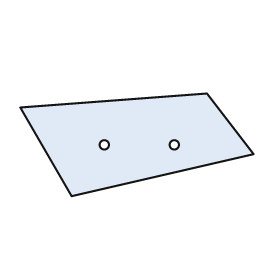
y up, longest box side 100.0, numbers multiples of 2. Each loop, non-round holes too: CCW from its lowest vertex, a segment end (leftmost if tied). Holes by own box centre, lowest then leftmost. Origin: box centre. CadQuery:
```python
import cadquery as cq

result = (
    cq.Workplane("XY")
    .moveTo(-28.0, -22.0)
    .lineTo(50.0, -4.0)
    .lineTo(30.0, 22.0)
    .lineTo(-50.0, 16.0)
    .close()
    .moveTo(-14.0, 0.0)
    .circle(2.0)
    .moveTo(16.0, 0.0)
    .circle(2.0)
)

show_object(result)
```